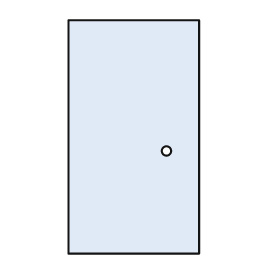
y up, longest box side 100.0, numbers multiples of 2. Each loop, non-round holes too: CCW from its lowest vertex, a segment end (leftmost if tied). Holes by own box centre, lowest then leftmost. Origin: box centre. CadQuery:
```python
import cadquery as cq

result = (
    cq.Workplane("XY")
    .moveTo(-28.0, -50.0)
    .lineTo(28.0, -50.0)
    .lineTo(28.0, 50.0)
    .lineTo(-28.0, 50.0)
    .close()
    .moveTo(14.0, -6.0)
    .circle(2.0)
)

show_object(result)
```